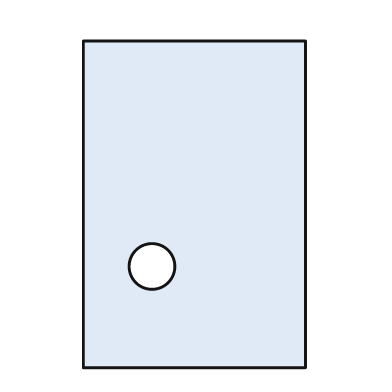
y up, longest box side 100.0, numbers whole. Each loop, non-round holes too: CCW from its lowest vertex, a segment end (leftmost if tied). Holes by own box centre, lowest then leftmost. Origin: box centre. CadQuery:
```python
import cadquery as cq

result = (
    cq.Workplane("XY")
    .moveTo(-34.0, -50.0)
    .lineTo(34.0, -50.0)
    .lineTo(34.0, 50.0)
    .lineTo(-34.0, 50.0)
    .close()
    .moveTo(-13.0, -19.0)
    .circle(7.0)
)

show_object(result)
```